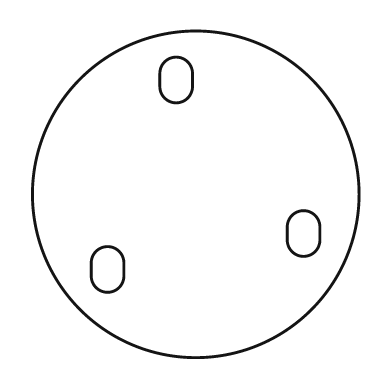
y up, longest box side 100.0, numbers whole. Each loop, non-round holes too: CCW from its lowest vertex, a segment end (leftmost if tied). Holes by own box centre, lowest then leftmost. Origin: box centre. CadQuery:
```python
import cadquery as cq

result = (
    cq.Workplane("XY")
    .moveTo(0.0, 0.0)
    .circle(50.0)
    .moveTo(-32.0, -25.0)
    .threePointArc((-27.0, -30.0), (-22.0, -25.0))
    .lineTo(-22.0, -21.0)
    .threePointArc((-27.0, -16.0), (-32.0, -21.0))
    .close()
    .moveTo(28.0, -14.0)
    .threePointArc((33.0, -19.0), (38.0, -14.0))
    .lineTo(38.0, -10.0)
    .threePointArc((33.0, -5.0), (28.0, -10.0))
    .close()
    .moveTo(-11.0, 33.0)
    .threePointArc((-6.0, 28.0), (-1.0, 33.0))
    .lineTo(-1.0, 37.0)
    .threePointArc((-6.0, 42.0), (-11.0, 37.0))
    .close()
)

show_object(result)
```